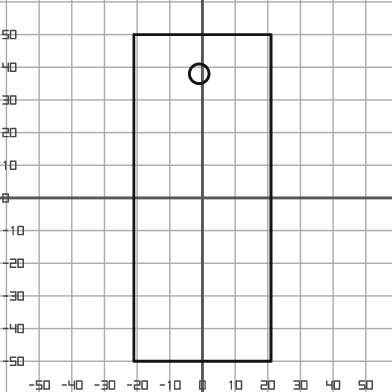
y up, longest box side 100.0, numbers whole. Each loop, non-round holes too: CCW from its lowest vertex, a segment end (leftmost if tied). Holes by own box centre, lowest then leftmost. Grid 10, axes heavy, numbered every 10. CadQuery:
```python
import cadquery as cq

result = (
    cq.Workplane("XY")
    .moveTo(-21.0, -50.0)
    .lineTo(21.0, -50.0)
    .lineTo(21.0, 50.0)
    .lineTo(-21.0, 50.0)
    .close()
    .moveTo(-1.0, 38.0)
    .circle(3.0)
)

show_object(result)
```